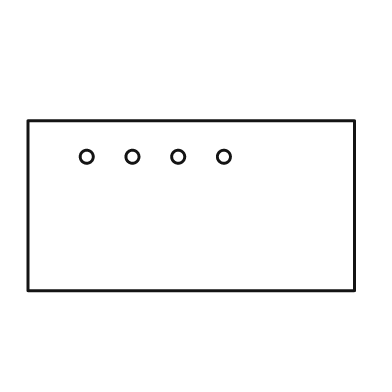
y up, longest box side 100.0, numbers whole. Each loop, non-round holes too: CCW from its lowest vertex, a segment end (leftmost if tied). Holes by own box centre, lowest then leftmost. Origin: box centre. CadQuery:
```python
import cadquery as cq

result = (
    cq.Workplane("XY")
    .moveTo(-50.0, -26.0)
    .lineTo(50.0, -26.0)
    .lineTo(50.0, 26.0)
    .lineTo(-50.0, 26.0)
    .close()
    .moveTo(-32.0, 15.0)
    .circle(2.0)
    .moveTo(-18.0, 15.0)
    .circle(2.0)
    .moveTo(-4.0, 15.0)
    .circle(2.0)
    .moveTo(10.0, 15.0)
    .circle(2.0)
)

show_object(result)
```